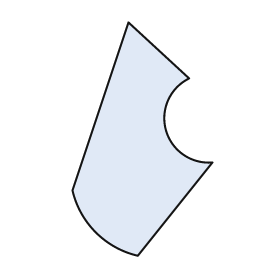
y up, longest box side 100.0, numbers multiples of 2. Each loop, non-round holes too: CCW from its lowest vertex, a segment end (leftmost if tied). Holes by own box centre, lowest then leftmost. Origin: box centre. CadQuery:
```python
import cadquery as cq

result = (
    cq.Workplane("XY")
    .moveTo(-2.0, -50.0)
    .lineTo(30.0, -10.0)
    .threePointArc((10.0, 4.0), (20.0, 26.0))
    .lineTo(-6.0, 50.0)
    .lineTo(-30.0, -22.0)
    .threePointArc((-20.0, -40.0), (-2.0, -50.0))
    .close()
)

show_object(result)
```